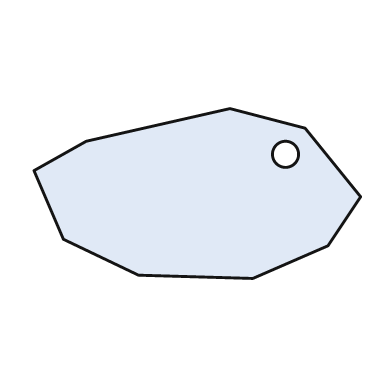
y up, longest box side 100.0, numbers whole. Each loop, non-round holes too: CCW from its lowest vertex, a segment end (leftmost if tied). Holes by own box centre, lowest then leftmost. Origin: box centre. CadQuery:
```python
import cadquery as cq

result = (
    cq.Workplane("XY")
    .moveTo(17.0, -26.0)
    .lineTo(40.0, -16.0)
    .lineTo(50.0, -1.0)
    .lineTo(33.0, 20.0)
    .lineTo(10.0, 26.0)
    .lineTo(-34.0, 16.0)
    .lineTo(-50.0, 7.0)
    .lineTo(-41.0, -14.0)
    .lineTo(-18.0, -25.0)
    .close()
    .moveTo(27.0, 12.0)
    .circle(4.0)
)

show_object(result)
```